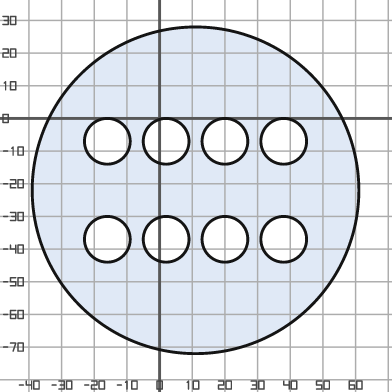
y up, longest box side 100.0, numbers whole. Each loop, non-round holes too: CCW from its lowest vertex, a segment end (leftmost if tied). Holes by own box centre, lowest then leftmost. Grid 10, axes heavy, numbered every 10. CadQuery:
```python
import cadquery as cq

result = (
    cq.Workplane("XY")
    .moveTo(11.0, -22.0)
    .circle(50.0)
    .moveTo(-16.0, -37.0)
    .circle(7.0)
    .moveTo(2.0, -37.0)
    .circle(7.0)
    .moveTo(20.0, -37.0)
    .circle(7.0)
    .moveTo(38.0, -37.0)
    .circle(7.0)
    .moveTo(-16.0, -7.0)
    .circle(7.0)
    .moveTo(2.0, -7.0)
    .circle(7.0)
    .moveTo(20.0, -7.0)
    .circle(7.0)
    .moveTo(38.0, -7.0)
    .circle(7.0)
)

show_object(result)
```